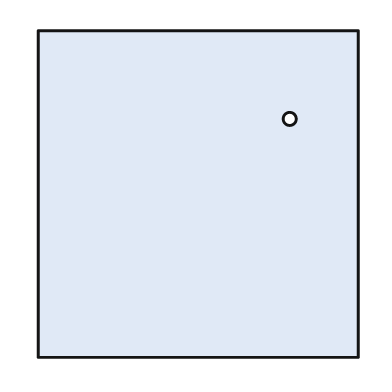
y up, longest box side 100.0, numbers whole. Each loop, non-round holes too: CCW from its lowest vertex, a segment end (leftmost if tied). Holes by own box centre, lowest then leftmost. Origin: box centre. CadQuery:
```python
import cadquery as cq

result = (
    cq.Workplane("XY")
    .moveTo(-49.0, -50.0)
    .lineTo(49.0, -50.0)
    .lineTo(49.0, 50.0)
    .lineTo(-49.0, 50.0)
    .close()
    .moveTo(28.0, 23.0)
    .circle(2.0)
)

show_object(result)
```